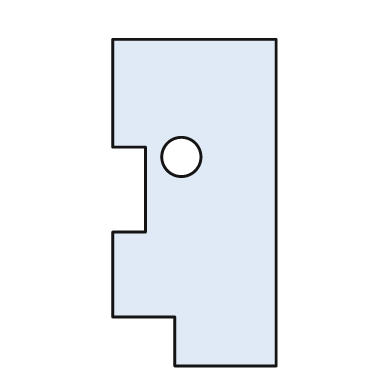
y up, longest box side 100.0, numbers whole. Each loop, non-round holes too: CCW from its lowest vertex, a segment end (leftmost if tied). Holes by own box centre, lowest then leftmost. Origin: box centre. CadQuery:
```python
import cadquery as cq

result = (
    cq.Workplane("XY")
    .moveTo(-6.0, -50.0)
    .lineTo(25.0, -50.0)
    .lineTo(25.0, 50.0)
    .lineTo(-25.0, 50.0)
    .lineTo(-25.0, 17.0)
    .lineTo(-15.0, 17.0)
    .lineTo(-15.0, -9.0)
    .lineTo(-25.0, -9.0)
    .lineTo(-25.0, -35.0)
    .lineTo(-6.0, -35.0)
    .close()
    .moveTo(-4.0, 14.0)
    .circle(6.0)
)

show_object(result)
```